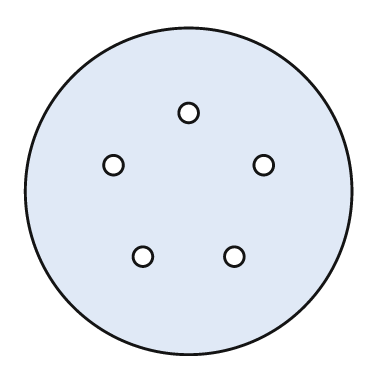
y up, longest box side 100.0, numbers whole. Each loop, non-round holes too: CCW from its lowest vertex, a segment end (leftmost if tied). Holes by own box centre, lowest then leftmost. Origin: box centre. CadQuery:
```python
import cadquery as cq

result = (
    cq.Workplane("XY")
    .moveTo(0.0, 0.0)
    .circle(50.0)
    .moveTo(-14.0, -20.0)
    .circle(3.0)
    .moveTo(14.0, -20.0)
    .circle(3.0)
    .moveTo(-23.0, 8.0)
    .circle(3.0)
    .moveTo(23.0, 8.0)
    .circle(3.0)
    .moveTo(0.0, 24.0)
    .circle(3.0)
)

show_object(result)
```